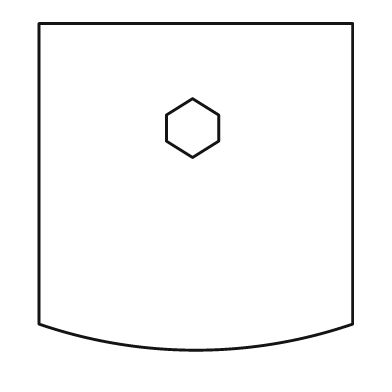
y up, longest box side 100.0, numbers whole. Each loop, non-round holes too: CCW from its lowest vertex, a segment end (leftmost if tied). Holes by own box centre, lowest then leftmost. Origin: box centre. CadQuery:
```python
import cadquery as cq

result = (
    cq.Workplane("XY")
    .moveTo(-48.0, -42.0)
    .threePointArc((0.0, -50.0), (48.0, -42.0))
    .lineTo(48.0, 50.0)
    .lineTo(-48.0, 50.0)
    .close()
    .moveTo(-1.0, 9.0)
    .lineTo(7.0, 14.0)
    .lineTo(7.0, 22.0)
    .lineTo(-1.0, 27.0)
    .lineTo(-9.0, 22.0)
    .lineTo(-9.0, 14.0)
    .close()
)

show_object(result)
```